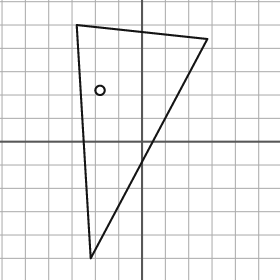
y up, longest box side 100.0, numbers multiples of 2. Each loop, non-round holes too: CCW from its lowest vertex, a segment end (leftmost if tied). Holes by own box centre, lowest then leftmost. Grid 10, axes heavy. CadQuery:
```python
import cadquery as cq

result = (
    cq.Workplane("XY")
    .moveTo(-22.0, -50.0)
    .lineTo(28.0, 44.0)
    .lineTo(-28.0, 50.0)
    .close()
    .moveTo(-18.0, 22.0)
    .circle(2.0)
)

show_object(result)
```